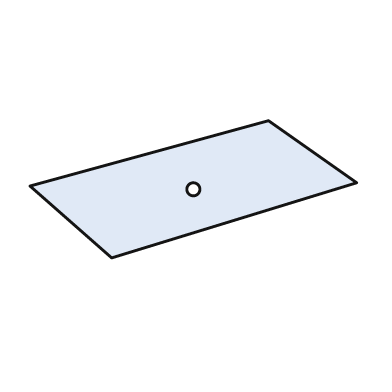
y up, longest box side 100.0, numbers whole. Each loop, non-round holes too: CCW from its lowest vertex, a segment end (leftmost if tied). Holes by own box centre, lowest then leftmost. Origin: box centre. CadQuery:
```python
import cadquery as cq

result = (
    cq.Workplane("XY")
    .moveTo(-25.0, -21.0)
    .lineTo(50.0, 2.0)
    .lineTo(23.0, 21.0)
    .lineTo(-50.0, 1.0)
    .close()
    .moveTo(0.0, 0.0)
    .circle(2.0)
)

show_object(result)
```